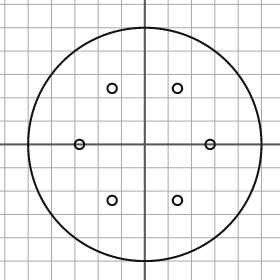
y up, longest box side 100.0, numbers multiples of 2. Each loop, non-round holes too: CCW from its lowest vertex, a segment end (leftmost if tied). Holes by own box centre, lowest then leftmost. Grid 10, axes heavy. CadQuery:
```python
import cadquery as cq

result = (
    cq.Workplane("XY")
    .moveTo(0.0, 0.0)
    .circle(50.0)
    .moveTo(-14.0, -24.0)
    .circle(2.0)
    .moveTo(14.0, -24.0)
    .circle(2.0)
    .moveTo(-28.0, 0.0)
    .circle(2.0)
    .moveTo(28.0, 0.0)
    .circle(2.0)
    .moveTo(-14.0, 24.0)
    .circle(2.0)
    .moveTo(14.0, 24.0)
    .circle(2.0)
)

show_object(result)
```